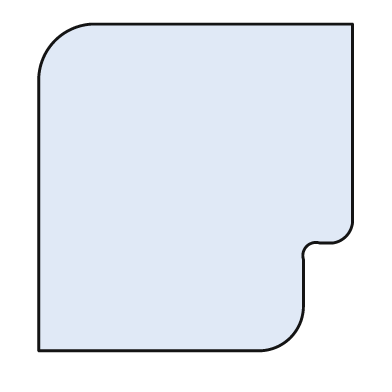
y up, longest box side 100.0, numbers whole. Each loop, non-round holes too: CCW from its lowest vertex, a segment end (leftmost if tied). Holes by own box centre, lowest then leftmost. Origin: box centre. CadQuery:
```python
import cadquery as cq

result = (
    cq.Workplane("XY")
    .moveTo(-48.0, -50.0)
    .lineTo(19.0, -50.0)
    .threePointArc((29.0, -46.0), (33.0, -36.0))
    .lineTo(33.0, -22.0)
    .threePointArc((34.0, -18.0), (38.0, -17.0))
    .lineTo(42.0, -17.0)
    .threePointArc((46.0, -15.0), (48.0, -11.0))
    .lineTo(48.0, 50.0)
    .lineTo(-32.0, 50.0)
    .threePointArc((-43.0, 45.0), (-48.0, 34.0))
    .close()
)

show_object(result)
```